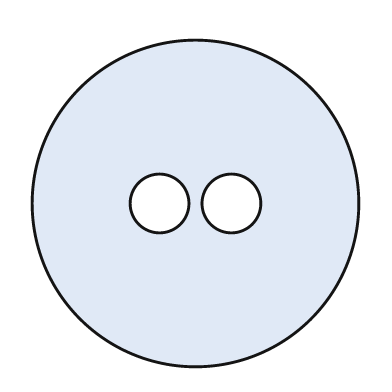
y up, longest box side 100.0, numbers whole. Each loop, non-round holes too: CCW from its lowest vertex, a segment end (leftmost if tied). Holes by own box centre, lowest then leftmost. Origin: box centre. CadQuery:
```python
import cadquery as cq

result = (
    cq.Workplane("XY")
    .moveTo(0.0, 0.0)
    .circle(50.0)
    .moveTo(-11.0, 0.0)
    .circle(9.0)
    .moveTo(11.0, 0.0)
    .circle(9.0)
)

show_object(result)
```